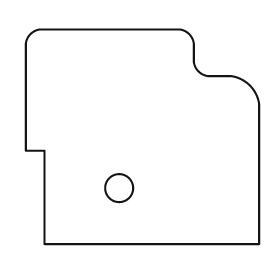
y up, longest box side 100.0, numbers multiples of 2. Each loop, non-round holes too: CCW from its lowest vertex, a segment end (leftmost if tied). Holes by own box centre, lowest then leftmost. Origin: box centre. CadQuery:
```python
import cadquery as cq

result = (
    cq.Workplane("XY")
    .moveTo(-42.0, -46.0)
    .lineTo(50.0, -46.0)
    .lineTo(50.0, 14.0)
    .threePointArc((46.0, 22.0), (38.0, 26.0))
    .lineTo(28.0, 26.0)
    .threePointArc((24.0, 28.0), (22.0, 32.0))
    .lineTo(22.0, 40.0)
    .threePointArc((20.0, 44.0), (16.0, 46.0))
    .lineTo(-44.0, 46.0)
    .threePointArc((-48.0, 44.0), (-50.0, 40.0))
    .lineTo(-50.0, -6.0)
    .lineTo(-42.0, -6.0)
    .close()
    .moveTo(-10.0, -22.0)
    .circle(6.0)
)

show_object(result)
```